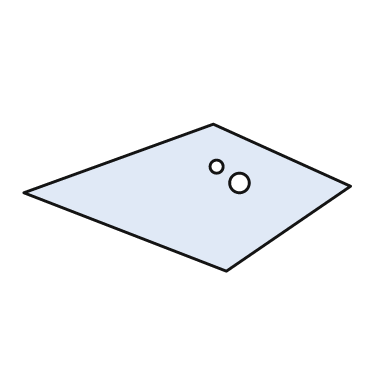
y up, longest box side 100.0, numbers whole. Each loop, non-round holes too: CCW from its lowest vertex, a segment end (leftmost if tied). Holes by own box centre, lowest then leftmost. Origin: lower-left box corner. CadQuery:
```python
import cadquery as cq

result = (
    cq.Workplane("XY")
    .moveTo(62.0, 0.0)
    .lineTo(100.0, 26.0)
    .lineTo(58.0, 45.0)
    .lineTo(0.0, 24.0)
    .close()
    .moveTo(66.0, 27.0)
    .circle(3.0)
    .moveTo(59.0, 32.0)
    .circle(2.0)
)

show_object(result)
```